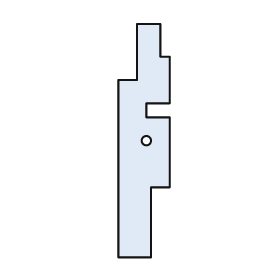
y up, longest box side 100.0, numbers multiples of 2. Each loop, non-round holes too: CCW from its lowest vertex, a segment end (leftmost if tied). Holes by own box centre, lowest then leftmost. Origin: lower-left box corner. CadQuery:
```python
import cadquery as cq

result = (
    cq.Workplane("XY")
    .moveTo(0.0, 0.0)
    .lineTo(14.0, 0.0)
    .lineTo(14.0, 30.0)
    .lineTo(22.0, 30.0)
    .lineTo(22.0, 60.0)
    .lineTo(12.0, 60.0)
    .lineTo(12.0, 66.0)
    .lineTo(22.0, 66.0)
    .lineTo(22.0, 86.0)
    .lineTo(18.0, 86.0)
    .lineTo(18.0, 100.0)
    .lineTo(8.0, 100.0)
    .lineTo(8.0, 76.0)
    .lineTo(0.0, 76.0)
    .close()
    .moveTo(12.0, 50.0)
    .circle(2.0)
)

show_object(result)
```